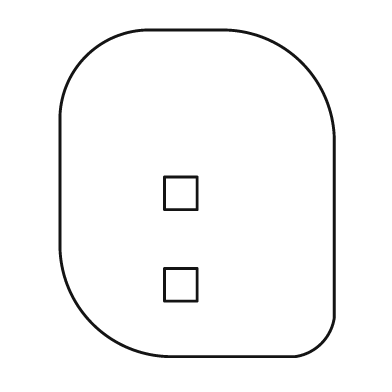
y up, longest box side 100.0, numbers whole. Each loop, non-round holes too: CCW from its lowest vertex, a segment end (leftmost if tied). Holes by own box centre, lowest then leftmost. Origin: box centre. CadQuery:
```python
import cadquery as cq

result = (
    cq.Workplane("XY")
    .moveTo(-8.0, -50.0)
    .lineTo(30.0, -50.0)
    .threePointArc((38.0, -46.0), (42.0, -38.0))
    .lineTo(42.0, 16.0)
    .threePointArc((32.0, 40.0), (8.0, 50.0))
    .lineTo(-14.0, 50.0)
    .threePointArc((-34.0, 42.0), (-42.0, 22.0))
    .lineTo(-42.0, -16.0)
    .threePointArc((-32.0, -40.0), (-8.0, -50.0))
    .close()
    .moveTo(-10.0, -33.0)
    .lineTo(0.0, -33.0)
    .lineTo(0.0, -23.0)
    .lineTo(-10.0, -23.0)
    .close()
    .moveTo(-10.0, -5.0)
    .lineTo(0.0, -5.0)
    .lineTo(0.0, 5.0)
    .lineTo(-10.0, 5.0)
    .close()
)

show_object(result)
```